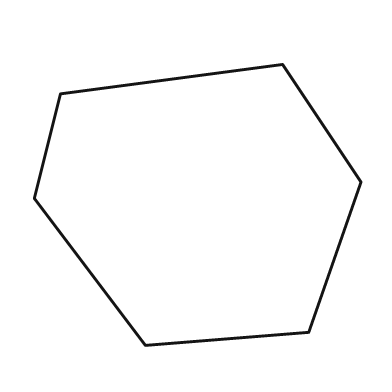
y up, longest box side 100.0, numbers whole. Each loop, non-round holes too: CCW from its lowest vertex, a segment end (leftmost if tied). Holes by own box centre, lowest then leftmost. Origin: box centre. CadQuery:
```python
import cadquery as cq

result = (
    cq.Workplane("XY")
    .moveTo(-16.0, -43.0)
    .lineTo(34.0, -39.0)
    .lineTo(50.0, 7.0)
    .lineTo(26.0, 43.0)
    .lineTo(-42.0, 34.0)
    .lineTo(-50.0, 2.0)
    .close()
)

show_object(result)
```